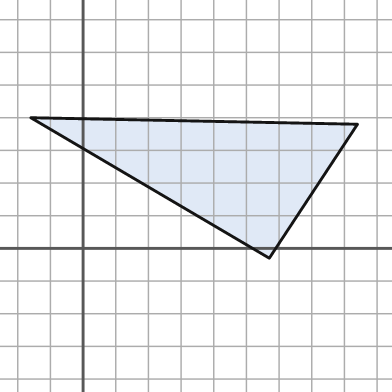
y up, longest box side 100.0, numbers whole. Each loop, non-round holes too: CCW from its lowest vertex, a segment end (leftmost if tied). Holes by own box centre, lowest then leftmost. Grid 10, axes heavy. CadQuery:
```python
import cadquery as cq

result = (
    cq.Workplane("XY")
    .moveTo(57.0, -3.0)
    .lineTo(84.0, 38.0)
    .lineTo(-16.0, 40.0)
    .close()
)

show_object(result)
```